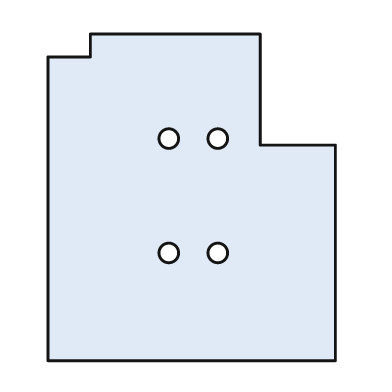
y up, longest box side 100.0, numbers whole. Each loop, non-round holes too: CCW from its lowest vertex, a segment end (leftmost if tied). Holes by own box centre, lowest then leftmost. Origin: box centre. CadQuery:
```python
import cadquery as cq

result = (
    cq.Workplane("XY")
    .moveTo(-44.0, -50.0)
    .lineTo(44.0, -50.0)
    .lineTo(44.0, 16.0)
    .lineTo(21.0, 16.0)
    .lineTo(21.0, 50.0)
    .lineTo(-31.0, 50.0)
    .lineTo(-31.0, 43.0)
    .lineTo(-44.0, 43.0)
    .close()
    .moveTo(-7.0, -17.0)
    .circle(3.0)
    .moveTo(8.0, -17.0)
    .circle(3.0)
    .moveTo(-7.0, 18.0)
    .circle(3.0)
    .moveTo(8.0, 18.0)
    .circle(3.0)
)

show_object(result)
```